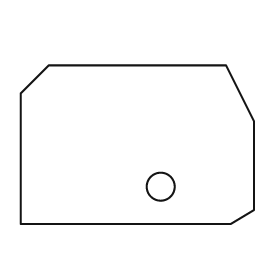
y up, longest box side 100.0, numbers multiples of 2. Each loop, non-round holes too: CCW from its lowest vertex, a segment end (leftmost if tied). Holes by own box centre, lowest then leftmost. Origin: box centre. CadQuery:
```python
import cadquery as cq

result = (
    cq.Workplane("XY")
    .moveTo(-50.0, -34.0)
    .lineTo(40.0, -34.0)
    .lineTo(50.0, -28.0)
    .lineTo(50.0, 10.0)
    .lineTo(38.0, 34.0)
    .lineTo(-38.0, 34.0)
    .lineTo(-50.0, 22.0)
    .close()
    .moveTo(10.0, -18.0)
    .circle(6.0)
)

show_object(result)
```